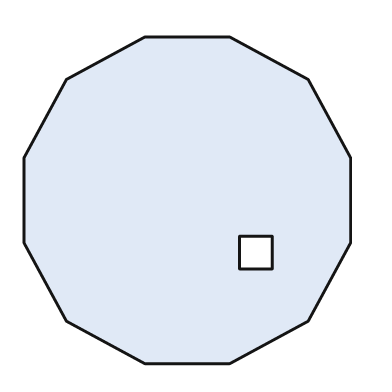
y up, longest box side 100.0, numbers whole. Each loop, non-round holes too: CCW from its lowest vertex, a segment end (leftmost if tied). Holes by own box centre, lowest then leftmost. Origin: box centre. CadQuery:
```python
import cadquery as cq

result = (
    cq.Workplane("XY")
    .moveTo(-13.0, -50.0)
    .lineTo(13.0, -50.0)
    .lineTo(37.0, -37.0)
    .lineTo(50.0, -13.0)
    .lineTo(50.0, 13.0)
    .lineTo(37.0, 37.0)
    .lineTo(13.0, 50.0)
    .lineTo(-13.0, 50.0)
    .lineTo(-37.0, 37.0)
    .lineTo(-50.0, 13.0)
    .lineTo(-50.0, -13.0)
    .lineTo(-37.0, -37.0)
    .close()
    .moveTo(16.0, -21.0)
    .lineTo(26.0, -21.0)
    .lineTo(26.0, -11.0)
    .lineTo(16.0, -11.0)
    .close()
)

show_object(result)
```